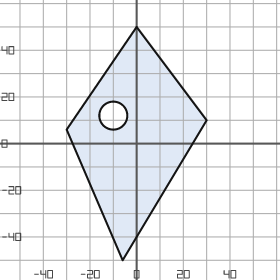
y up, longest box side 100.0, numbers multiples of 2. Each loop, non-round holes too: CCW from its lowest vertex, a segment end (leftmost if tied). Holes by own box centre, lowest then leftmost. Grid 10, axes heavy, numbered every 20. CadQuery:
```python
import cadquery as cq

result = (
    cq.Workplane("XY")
    .moveTo(-6.0, -50.0)
    .lineTo(30.0, 10.0)
    .lineTo(0.0, 50.0)
    .lineTo(-30.0, 6.0)
    .close()
    .moveTo(-10.0, 12.0)
    .circle(6.0)
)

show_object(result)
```